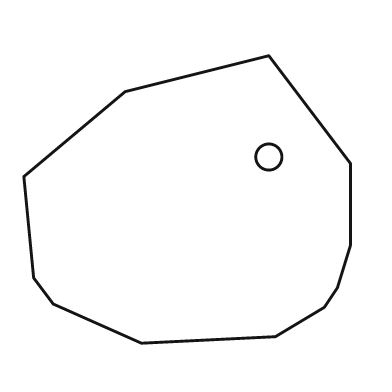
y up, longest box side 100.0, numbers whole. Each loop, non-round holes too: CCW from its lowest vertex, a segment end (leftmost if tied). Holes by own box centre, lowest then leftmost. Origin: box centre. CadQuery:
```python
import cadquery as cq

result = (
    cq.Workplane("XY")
    .moveTo(-14.0, -44.0)
    .lineTo(27.0, -42.0)
    .lineTo(42.0, -33.0)
    .lineTo(46.0, -27.0)
    .lineTo(50.0, -14.0)
    .lineTo(50.0, 11.0)
    .lineTo(25.0, 44.0)
    .lineTo(-19.0, 33.0)
    .lineTo(-50.0, 7.0)
    .lineTo(-47.0, -24.0)
    .lineTo(-41.0, -32.0)
    .close()
    .moveTo(25.0, 13.0)
    .circle(4.0)
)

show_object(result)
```